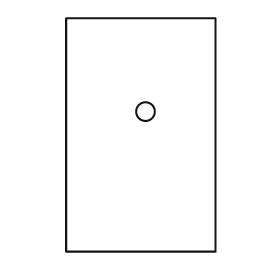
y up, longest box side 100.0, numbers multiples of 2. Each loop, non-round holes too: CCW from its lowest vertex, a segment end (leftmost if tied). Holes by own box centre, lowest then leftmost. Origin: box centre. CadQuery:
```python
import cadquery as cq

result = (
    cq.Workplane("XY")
    .moveTo(-32.0, -50.0)
    .lineTo(32.0, -50.0)
    .lineTo(32.0, 50.0)
    .lineTo(-32.0, 50.0)
    .close()
    .moveTo(2.0, 10.0)
    .circle(4.0)
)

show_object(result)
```